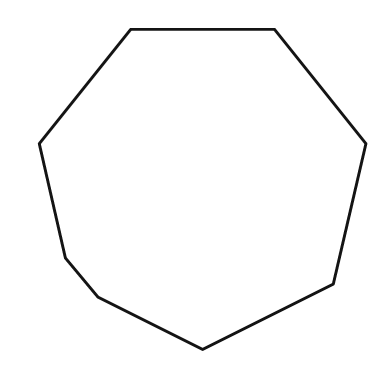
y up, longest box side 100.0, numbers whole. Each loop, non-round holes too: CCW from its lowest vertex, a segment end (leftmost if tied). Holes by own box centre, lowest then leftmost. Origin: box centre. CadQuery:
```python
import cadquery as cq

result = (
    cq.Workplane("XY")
    .moveTo(0.0, -49.0)
    .lineTo(40.0, -29.0)
    .lineTo(50.0, 14.0)
    .lineTo(22.0, 49.0)
    .lineTo(-22.0, 49.0)
    .lineTo(-50.0, 14.0)
    .lineTo(-42.0, -21.0)
    .lineTo(-32.0, -33.0)
    .close()
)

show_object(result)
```